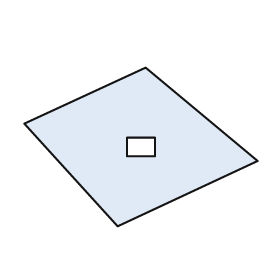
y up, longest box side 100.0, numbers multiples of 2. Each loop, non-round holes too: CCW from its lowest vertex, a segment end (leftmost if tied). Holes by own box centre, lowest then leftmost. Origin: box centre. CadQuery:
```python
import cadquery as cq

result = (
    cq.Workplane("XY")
    .moveTo(-10.0, -34.0)
    .lineTo(50.0, -6.0)
    .lineTo(2.0, 34.0)
    .lineTo(-50.0, 10.0)
    .close()
    .moveTo(-6.0, -4.0)
    .lineTo(6.0, -4.0)
    .lineTo(6.0, 4.0)
    .lineTo(-6.0, 4.0)
    .close()
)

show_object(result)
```